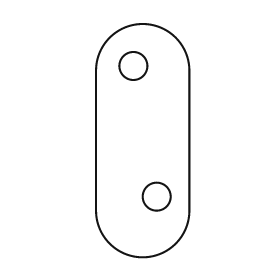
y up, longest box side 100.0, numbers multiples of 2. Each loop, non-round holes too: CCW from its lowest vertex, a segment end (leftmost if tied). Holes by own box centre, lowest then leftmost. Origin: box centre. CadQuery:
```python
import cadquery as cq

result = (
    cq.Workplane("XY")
    .moveTo(-20.0, -30.0)
    .threePointArc((0.0, -50.0), (20.0, -30.0))
    .lineTo(20.0, 30.0)
    .threePointArc((0.0, 50.0), (-20.0, 30.0))
    .close()
    .moveTo(6.0, -24.0)
    .circle(6.0)
    .moveTo(-4.0, 32.0)
    .circle(6.0)
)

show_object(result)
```